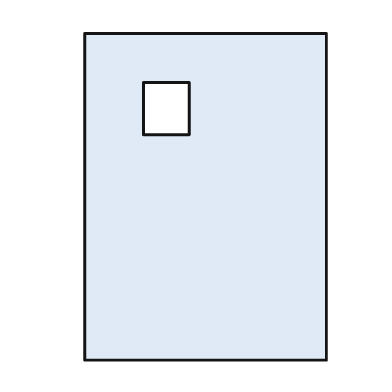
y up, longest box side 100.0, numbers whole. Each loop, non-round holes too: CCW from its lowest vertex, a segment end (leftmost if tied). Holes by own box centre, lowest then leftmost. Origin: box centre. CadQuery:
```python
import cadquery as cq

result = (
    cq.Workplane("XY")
    .moveTo(-37.0, -50.0)
    .lineTo(37.0, -50.0)
    .lineTo(37.0, 50.0)
    .lineTo(-37.0, 50.0)
    .close()
    .moveTo(-19.0, 19.0)
    .lineTo(-5.0, 19.0)
    .lineTo(-5.0, 35.0)
    .lineTo(-19.0, 35.0)
    .close()
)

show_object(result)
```